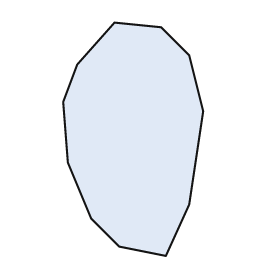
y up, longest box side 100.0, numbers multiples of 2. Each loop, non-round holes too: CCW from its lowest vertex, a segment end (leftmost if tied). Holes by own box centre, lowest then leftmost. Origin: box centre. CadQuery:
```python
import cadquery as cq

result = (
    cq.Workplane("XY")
    .moveTo(14.0, -50.0)
    .lineTo(24.0, -28.0)
    .lineTo(30.0, 12.0)
    .lineTo(24.0, 36.0)
    .lineTo(12.0, 48.0)
    .lineTo(-8.0, 50.0)
    .lineTo(-24.0, 32.0)
    .lineTo(-30.0, 16.0)
    .lineTo(-28.0, -10.0)
    .lineTo(-18.0, -34.0)
    .lineTo(-6.0, -46.0)
    .close()
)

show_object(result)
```